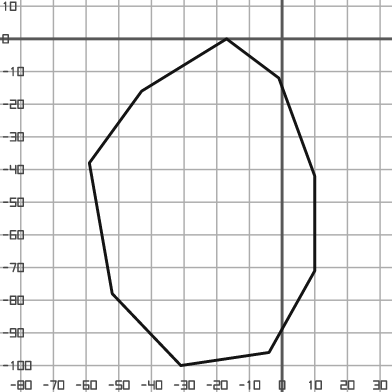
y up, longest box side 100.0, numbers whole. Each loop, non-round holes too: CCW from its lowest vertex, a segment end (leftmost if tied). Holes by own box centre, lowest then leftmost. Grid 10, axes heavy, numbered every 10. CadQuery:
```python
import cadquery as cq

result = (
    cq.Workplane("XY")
    .moveTo(-31.0, -100.0)
    .lineTo(-4.0, -96.0)
    .lineTo(10.0, -71.0)
    .lineTo(10.0, -42.0)
    .lineTo(-1.0, -12.0)
    .lineTo(-17.0, 0.0)
    .lineTo(-43.0, -16.0)
    .lineTo(-59.0, -38.0)
    .lineTo(-52.0, -78.0)
    .close()
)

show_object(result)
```